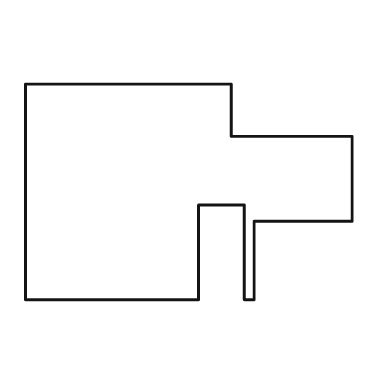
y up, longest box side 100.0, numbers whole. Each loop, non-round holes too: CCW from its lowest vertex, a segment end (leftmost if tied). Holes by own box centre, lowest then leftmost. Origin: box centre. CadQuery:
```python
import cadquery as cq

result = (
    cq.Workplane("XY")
    .moveTo(-50.0, -33.0)
    .lineTo(3.0, -33.0)
    .lineTo(3.0, -4.0)
    .lineTo(17.0, -4.0)
    .lineTo(17.0, -33.0)
    .lineTo(20.0, -33.0)
    .lineTo(20.0, -9.0)
    .lineTo(50.0, -9.0)
    .lineTo(50.0, 17.0)
    .lineTo(13.0, 17.0)
    .lineTo(13.0, 33.0)
    .lineTo(-50.0, 33.0)
    .close()
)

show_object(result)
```